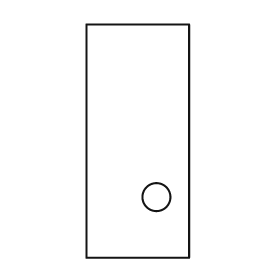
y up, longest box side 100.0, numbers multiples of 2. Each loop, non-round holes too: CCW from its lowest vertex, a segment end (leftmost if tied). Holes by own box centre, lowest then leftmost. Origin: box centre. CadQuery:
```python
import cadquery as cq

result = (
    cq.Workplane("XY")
    .moveTo(-22.0, -50.0)
    .lineTo(22.0, -50.0)
    .lineTo(22.0, 50.0)
    .lineTo(-22.0, 50.0)
    .close()
    .moveTo(8.0, -24.0)
    .circle(6.0)
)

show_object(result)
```